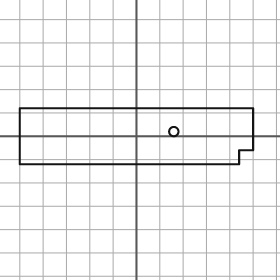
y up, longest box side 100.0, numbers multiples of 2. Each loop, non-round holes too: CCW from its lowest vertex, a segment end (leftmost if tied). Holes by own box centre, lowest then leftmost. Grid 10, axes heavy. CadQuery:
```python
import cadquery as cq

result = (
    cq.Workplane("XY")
    .moveTo(-50.0, -12.0)
    .lineTo(44.0, -12.0)
    .lineTo(44.0, -6.0)
    .lineTo(50.0, -6.0)
    .lineTo(50.0, 12.0)
    .lineTo(-50.0, 12.0)
    .close()
    .moveTo(16.0, 2.0)
    .circle(2.0)
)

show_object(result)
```